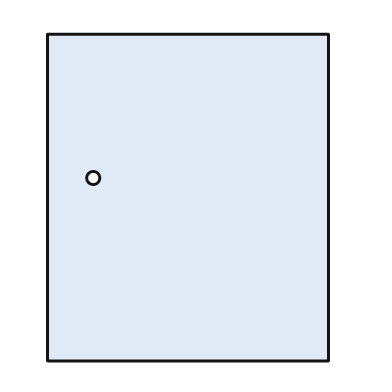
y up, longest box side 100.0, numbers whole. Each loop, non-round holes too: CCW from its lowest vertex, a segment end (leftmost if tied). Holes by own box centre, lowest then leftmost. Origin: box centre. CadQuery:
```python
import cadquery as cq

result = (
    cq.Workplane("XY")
    .moveTo(-43.0, -50.0)
    .lineTo(43.0, -50.0)
    .lineTo(43.0, 50.0)
    .lineTo(-43.0, 50.0)
    .close()
    .moveTo(-29.0, 6.0)
    .circle(2.0)
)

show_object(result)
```